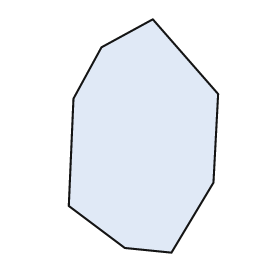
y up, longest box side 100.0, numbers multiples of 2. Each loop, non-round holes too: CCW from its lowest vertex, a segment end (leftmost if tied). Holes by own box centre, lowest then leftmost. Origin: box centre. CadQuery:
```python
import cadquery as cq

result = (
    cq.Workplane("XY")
    .moveTo(12.0, -50.0)
    .lineTo(30.0, -20.0)
    .lineTo(32.0, 18.0)
    .lineTo(4.0, 50.0)
    .lineTo(-18.0, 38.0)
    .lineTo(-30.0, 16.0)
    .lineTo(-32.0, -30.0)
    .lineTo(-8.0, -48.0)
    .close()
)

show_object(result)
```